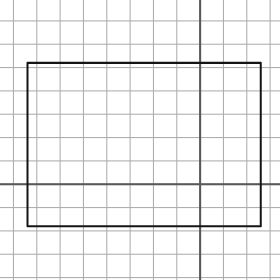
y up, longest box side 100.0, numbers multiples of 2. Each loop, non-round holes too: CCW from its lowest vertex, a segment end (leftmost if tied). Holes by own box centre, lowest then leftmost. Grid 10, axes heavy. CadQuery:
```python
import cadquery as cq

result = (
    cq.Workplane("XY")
    .moveTo(-74.0, -18.0)
    .lineTo(26.0, -18.0)
    .lineTo(26.0, 52.0)
    .lineTo(-74.0, 52.0)
    .close()
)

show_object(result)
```